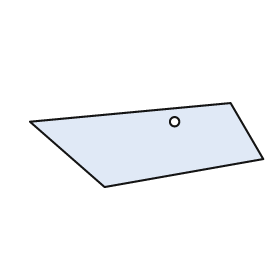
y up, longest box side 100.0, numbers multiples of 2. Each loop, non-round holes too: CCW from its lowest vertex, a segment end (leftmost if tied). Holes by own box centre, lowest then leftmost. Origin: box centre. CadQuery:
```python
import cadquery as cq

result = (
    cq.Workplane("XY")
    .moveTo(-18.0, -18.0)
    .lineTo(50.0, -6.0)
    .lineTo(36.0, 18.0)
    .lineTo(-50.0, 10.0)
    .close()
    .moveTo(12.0, 10.0)
    .circle(2.0)
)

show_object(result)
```